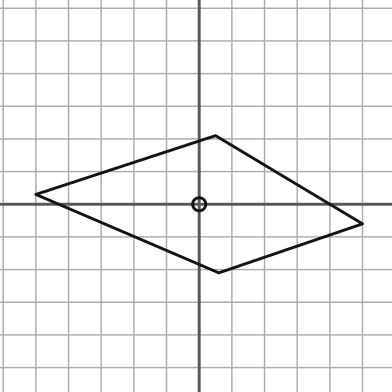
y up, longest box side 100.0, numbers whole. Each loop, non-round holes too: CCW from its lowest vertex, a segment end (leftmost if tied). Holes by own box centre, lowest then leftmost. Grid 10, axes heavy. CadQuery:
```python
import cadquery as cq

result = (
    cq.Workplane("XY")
    .moveTo(6.0, -21.0)
    .lineTo(50.0, -6.0)
    .lineTo(5.0, 21.0)
    .lineTo(-50.0, 3.0)
    .close()
    .moveTo(0.0, 0.0)
    .circle(2.0)
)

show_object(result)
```